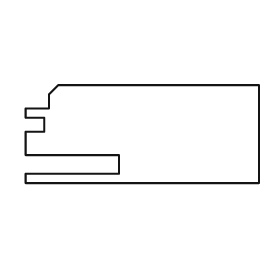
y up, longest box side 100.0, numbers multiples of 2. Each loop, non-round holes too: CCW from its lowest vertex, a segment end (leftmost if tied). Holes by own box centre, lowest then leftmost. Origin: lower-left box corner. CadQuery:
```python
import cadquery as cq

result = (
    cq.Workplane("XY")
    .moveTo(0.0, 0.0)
    .lineTo(100.0, 0.0)
    .lineTo(100.0, 42.0)
    .lineTo(14.0, 42.0)
    .lineTo(10.0, 38.0)
    .lineTo(10.0, 32.0)
    .lineTo(0.0, 32.0)
    .lineTo(0.0, 28.0)
    .lineTo(8.0, 28.0)
    .lineTo(8.0, 22.0)
    .lineTo(0.0, 22.0)
    .lineTo(0.0, 12.0)
    .lineTo(40.0, 12.0)
    .lineTo(40.0, 4.0)
    .lineTo(0.0, 4.0)
    .close()
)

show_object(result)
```